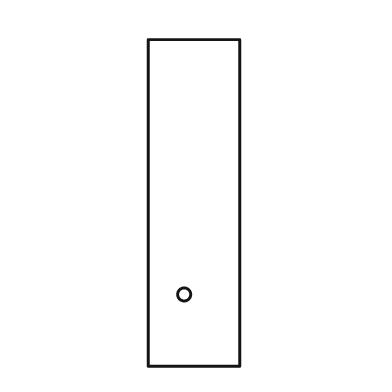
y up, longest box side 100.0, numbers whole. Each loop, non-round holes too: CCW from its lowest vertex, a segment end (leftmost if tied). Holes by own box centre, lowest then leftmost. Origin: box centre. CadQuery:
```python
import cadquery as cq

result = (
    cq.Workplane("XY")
    .moveTo(-14.0, -50.0)
    .lineTo(14.0, -50.0)
    .lineTo(14.0, 50.0)
    .lineTo(-14.0, 50.0)
    .close()
    .moveTo(-3.0, -28.0)
    .circle(2.0)
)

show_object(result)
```